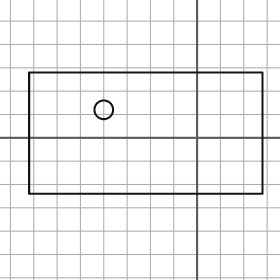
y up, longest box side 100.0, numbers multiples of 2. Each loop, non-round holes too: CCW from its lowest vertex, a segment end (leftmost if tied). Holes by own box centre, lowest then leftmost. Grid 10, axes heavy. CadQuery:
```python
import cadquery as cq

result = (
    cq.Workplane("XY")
    .moveTo(-72.0, -24.0)
    .lineTo(28.0, -24.0)
    .lineTo(28.0, 28.0)
    .lineTo(-72.0, 28.0)
    .close()
    .moveTo(-40.0, 12.0)
    .circle(4.0)
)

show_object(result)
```